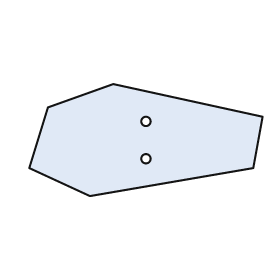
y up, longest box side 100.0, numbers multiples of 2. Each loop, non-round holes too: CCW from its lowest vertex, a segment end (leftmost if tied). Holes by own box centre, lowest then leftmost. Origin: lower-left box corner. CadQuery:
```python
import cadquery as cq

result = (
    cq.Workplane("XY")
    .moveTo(26.0, 0.0)
    .lineTo(96.0, 12.0)
    .lineTo(100.0, 34.0)
    .lineTo(36.0, 48.0)
    .lineTo(8.0, 38.0)
    .lineTo(0.0, 12.0)
    .close()
    .moveTo(50.0, 16.0)
    .circle(2.0)
    .moveTo(50.0, 32.0)
    .circle(2.0)
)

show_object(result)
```